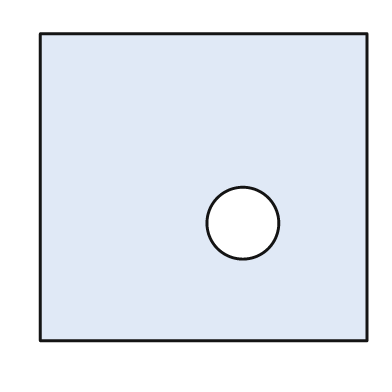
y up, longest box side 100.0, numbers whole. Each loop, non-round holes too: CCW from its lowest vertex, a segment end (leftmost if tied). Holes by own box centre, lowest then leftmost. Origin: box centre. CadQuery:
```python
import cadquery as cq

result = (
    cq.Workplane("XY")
    .moveTo(-50.0, -47.0)
    .lineTo(50.0, -47.0)
    .lineTo(50.0, 47.0)
    .lineTo(-50.0, 47.0)
    .close()
    .moveTo(12.0, -11.0)
    .circle(11.0)
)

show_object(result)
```